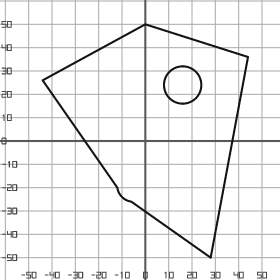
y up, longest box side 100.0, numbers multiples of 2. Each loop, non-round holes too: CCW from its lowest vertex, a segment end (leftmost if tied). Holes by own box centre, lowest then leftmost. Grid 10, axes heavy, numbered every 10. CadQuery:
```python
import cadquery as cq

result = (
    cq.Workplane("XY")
    .moveTo(28.0, -50.0)
    .lineTo(44.0, 36.0)
    .lineTo(0.0, 50.0)
    .lineTo(-44.0, 26.0)
    .lineTo(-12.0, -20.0)
    .threePointArc((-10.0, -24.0), (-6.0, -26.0))
    .close()
    .moveTo(16.0, 24.0)
    .circle(8.0)
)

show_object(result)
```